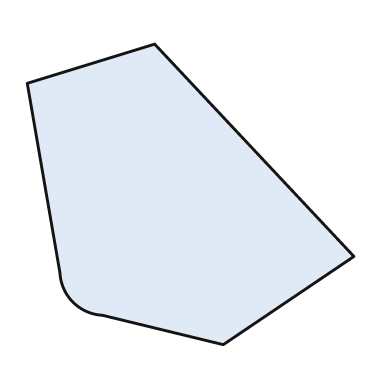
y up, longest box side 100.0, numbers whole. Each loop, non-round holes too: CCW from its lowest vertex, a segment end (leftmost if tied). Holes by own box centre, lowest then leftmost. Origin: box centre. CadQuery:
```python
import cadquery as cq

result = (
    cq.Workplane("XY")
    .moveTo(10.0, -46.0)
    .lineTo(50.0, -19.0)
    .lineTo(-11.0, 46.0)
    .lineTo(-50.0, 34.0)
    .lineTo(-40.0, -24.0)
    .threePointArc((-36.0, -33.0), (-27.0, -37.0))
    .close()
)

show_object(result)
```